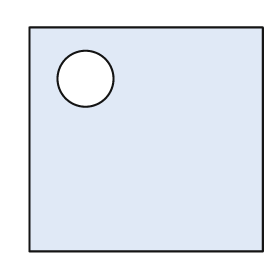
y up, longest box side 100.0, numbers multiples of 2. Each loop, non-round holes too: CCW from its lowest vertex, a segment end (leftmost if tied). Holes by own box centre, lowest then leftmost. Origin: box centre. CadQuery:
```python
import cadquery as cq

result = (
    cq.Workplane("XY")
    .moveTo(-50.0, -48.0)
    .lineTo(50.0, -48.0)
    .lineTo(50.0, 48.0)
    .lineTo(-50.0, 48.0)
    .close()
    .moveTo(-26.0, 26.0)
    .circle(12.0)
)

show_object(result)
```